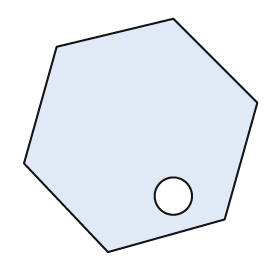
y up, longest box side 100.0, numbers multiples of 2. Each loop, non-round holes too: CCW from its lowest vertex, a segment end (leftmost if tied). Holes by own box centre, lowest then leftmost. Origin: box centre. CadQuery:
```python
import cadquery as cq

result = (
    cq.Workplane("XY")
    .moveTo(-14.0, -50.0)
    .lineTo(36.0, -36.0)
    .lineTo(50.0, 14.0)
    .lineTo(14.0, 50.0)
    .lineTo(-36.0, 38.0)
    .lineTo(-50.0, -12.0)
    .close()
    .moveTo(14.0, -26.0)
    .circle(8.0)
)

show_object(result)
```